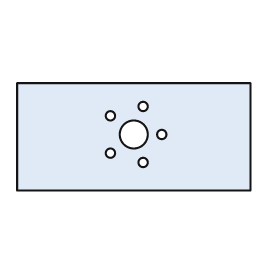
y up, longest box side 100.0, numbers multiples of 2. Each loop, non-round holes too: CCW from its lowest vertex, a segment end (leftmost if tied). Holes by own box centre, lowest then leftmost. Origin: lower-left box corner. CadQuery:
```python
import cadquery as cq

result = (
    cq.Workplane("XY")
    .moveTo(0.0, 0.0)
    .lineTo(100.0, 0.0)
    .lineTo(100.0, 46.0)
    .lineTo(0.0, 46.0)
    .close()
    .moveTo(54.0, 12.0)
    .circle(2.0)
    .moveTo(40.0, 16.0)
    .circle(2.0)
    .moveTo(50.0, 24.0)
    .circle(6.0)
    .moveTo(62.0, 24.0)
    .circle(2.0)
    .moveTo(40.0, 32.0)
    .circle(2.0)
    .moveTo(54.0, 36.0)
    .circle(2.0)
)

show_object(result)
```